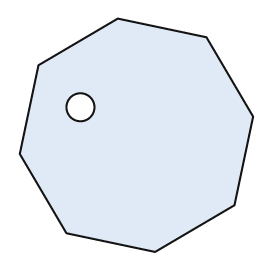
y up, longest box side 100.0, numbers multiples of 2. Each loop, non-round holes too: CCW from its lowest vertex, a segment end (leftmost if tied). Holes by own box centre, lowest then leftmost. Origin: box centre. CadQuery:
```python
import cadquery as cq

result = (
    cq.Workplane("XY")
    .moveTo(8.0, -50.0)
    .lineTo(42.0, -30.0)
    .lineTo(50.0, 8.0)
    .lineTo(30.0, 42.0)
    .lineTo(-8.0, 50.0)
    .lineTo(-42.0, 30.0)
    .lineTo(-50.0, -8.0)
    .lineTo(-30.0, -42.0)
    .close()
    .moveTo(-24.0, 12.0)
    .circle(6.0)
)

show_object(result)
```